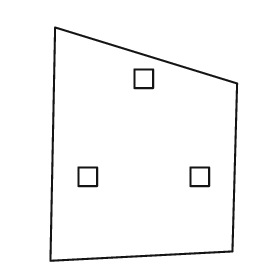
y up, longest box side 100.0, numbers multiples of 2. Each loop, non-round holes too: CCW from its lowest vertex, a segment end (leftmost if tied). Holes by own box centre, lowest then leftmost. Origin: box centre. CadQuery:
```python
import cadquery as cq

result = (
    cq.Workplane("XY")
    .moveTo(-40.0, -50.0)
    .lineTo(38.0, -46.0)
    .lineTo(40.0, 26.0)
    .lineTo(-38.0, 50.0)
    .close()
    .moveTo(-28.0, -18.0)
    .lineTo(-20.0, -18.0)
    .lineTo(-20.0, -10.0)
    .lineTo(-28.0, -10.0)
    .close()
    .moveTo(20.0, -18.0)
    .lineTo(28.0, -18.0)
    .lineTo(28.0, -10.0)
    .lineTo(20.0, -10.0)
    .close()
    .moveTo(-4.0, 24.0)
    .lineTo(4.0, 24.0)
    .lineTo(4.0, 32.0)
    .lineTo(-4.0, 32.0)
    .close()
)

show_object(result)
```